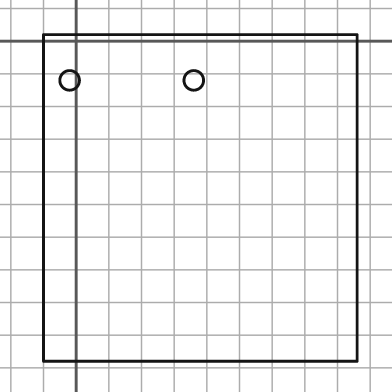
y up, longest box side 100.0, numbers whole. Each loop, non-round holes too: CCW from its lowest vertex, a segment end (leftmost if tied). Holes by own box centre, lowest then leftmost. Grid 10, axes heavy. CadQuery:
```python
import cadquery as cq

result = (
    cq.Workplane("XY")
    .moveTo(-10.0, -98.0)
    .lineTo(86.0, -98.0)
    .lineTo(86.0, 2.0)
    .lineTo(-10.0, 2.0)
    .close()
    .moveTo(-2.0, -12.0)
    .circle(3.0)
    .moveTo(36.0, -12.0)
    .circle(3.0)
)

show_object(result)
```